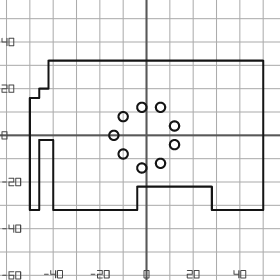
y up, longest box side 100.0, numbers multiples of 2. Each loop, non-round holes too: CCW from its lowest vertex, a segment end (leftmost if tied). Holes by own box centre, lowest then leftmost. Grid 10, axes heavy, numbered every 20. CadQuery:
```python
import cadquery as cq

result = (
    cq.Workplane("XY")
    .moveTo(-50.0, -32.0)
    .lineTo(-46.0, -32.0)
    .lineTo(-46.0, -2.0)
    .lineTo(-40.0, -2.0)
    .lineTo(-40.0, -32.0)
    .lineTo(-4.0, -32.0)
    .lineTo(-4.0, -22.0)
    .lineTo(28.0, -22.0)
    .lineTo(28.0, -32.0)
    .lineTo(50.0, -32.0)
    .lineTo(50.0, 32.0)
    .lineTo(-42.0, 32.0)
    .lineTo(-42.0, 20.0)
    .lineTo(-46.0, 20.0)
    .lineTo(-46.0, 16.0)
    .lineTo(-50.0, 16.0)
    .close()
    .moveTo(-2.0, -14.0)
    .circle(2.0)
    .moveTo(6.0, -12.0)
    .circle(2.0)
    .moveTo(-10.0, -8.0)
    .circle(2.0)
    .moveTo(12.0, -4.0)
    .circle(2.0)
    .moveTo(-14.0, 0.0)
    .circle(2.0)
    .moveTo(12.0, 4.0)
    .circle(2.0)
    .moveTo(-10.0, 8.0)
    .circle(2.0)
    .moveTo(-2.0, 12.0)
    .circle(2.0)
    .moveTo(6.0, 12.0)
    .circle(2.0)
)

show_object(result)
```